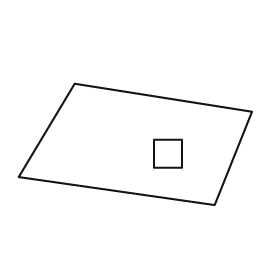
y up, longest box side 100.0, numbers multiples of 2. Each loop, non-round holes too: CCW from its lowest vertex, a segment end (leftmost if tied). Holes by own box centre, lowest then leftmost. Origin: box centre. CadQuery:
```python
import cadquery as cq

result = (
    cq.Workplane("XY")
    .moveTo(34.0, -26.0)
    .lineTo(50.0, 14.0)
    .lineTo(-26.0, 26.0)
    .lineTo(-50.0, -14.0)
    .close()
    .moveTo(8.0, -10.0)
    .lineTo(20.0, -10.0)
    .lineTo(20.0, 2.0)
    .lineTo(8.0, 2.0)
    .close()
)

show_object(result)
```